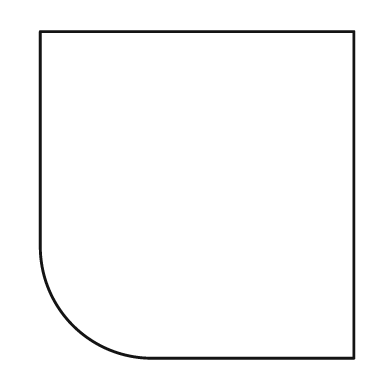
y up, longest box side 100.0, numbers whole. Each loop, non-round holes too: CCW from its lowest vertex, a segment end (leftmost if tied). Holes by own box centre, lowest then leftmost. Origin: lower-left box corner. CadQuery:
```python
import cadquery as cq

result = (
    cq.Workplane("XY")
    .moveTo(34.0, 0.0)
    .lineTo(96.0, 0.0)
    .lineTo(96.0, 100.0)
    .lineTo(0.0, 100.0)
    .lineTo(0.0, 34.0)
    .threePointArc((10.0, 10.0), (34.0, 0.0))
    .close()
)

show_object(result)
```